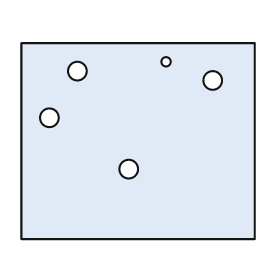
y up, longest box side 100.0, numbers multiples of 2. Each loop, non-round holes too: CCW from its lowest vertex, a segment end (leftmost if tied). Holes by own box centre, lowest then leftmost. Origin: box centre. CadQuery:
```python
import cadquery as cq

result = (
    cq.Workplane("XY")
    .moveTo(-50.0, -42.0)
    .lineTo(50.0, -42.0)
    .lineTo(50.0, 42.0)
    .lineTo(-50.0, 42.0)
    .close()
    .moveTo(-4.0, -12.0)
    .circle(4.0)
    .moveTo(-38.0, 10.0)
    .circle(4.0)
    .moveTo(32.0, 26.0)
    .circle(4.0)
    .moveTo(-26.0, 30.0)
    .circle(4.0)
    .moveTo(12.0, 34.0)
    .circle(2.0)
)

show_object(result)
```